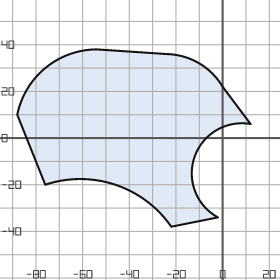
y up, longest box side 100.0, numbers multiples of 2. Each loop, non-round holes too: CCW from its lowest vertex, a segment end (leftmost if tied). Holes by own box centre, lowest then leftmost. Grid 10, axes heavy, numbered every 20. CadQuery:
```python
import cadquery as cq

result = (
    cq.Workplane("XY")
    .moveTo(-22.0, -38.0)
    .lineTo(-2.0, -34.0)
    .threePointArc((-12.0, -8.0), (12.0, 6.0))
    .lineTo(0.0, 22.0)
    .threePointArc((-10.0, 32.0), (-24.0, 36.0))
    .lineTo(-54.0, 38.0)
    .threePointArc((-76.0, 30.0), (-88.0, 10.0))
    .lineTo(-76.0, -20.0)
    .threePointArc((-46.0, -20.0), (-22.0, -38.0))
    .close()
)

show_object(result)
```